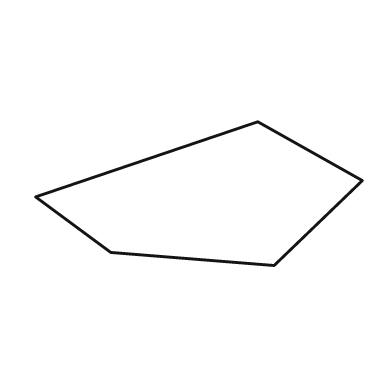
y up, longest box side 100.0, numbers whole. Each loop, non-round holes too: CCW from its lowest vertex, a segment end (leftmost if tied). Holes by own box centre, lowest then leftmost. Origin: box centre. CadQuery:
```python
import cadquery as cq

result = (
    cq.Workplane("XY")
    .moveTo(23.0, -22.0)
    .lineTo(50.0, 4.0)
    .lineTo(18.0, 22.0)
    .lineTo(-50.0, -1.0)
    .lineTo(-27.0, -18.0)
    .close()
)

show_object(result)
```